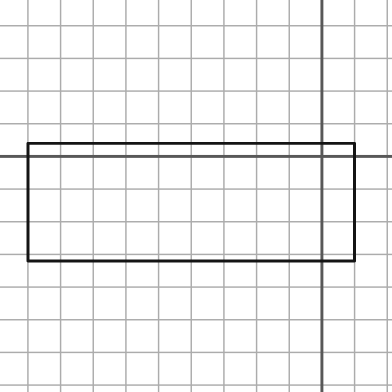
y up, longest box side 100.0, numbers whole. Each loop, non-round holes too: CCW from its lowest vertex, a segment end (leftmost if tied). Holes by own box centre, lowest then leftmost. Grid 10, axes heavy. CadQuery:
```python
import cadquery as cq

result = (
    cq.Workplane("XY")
    .moveTo(-90.0, -32.0)
    .lineTo(10.0, -32.0)
    .lineTo(10.0, 4.0)
    .lineTo(-90.0, 4.0)
    .close()
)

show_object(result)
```